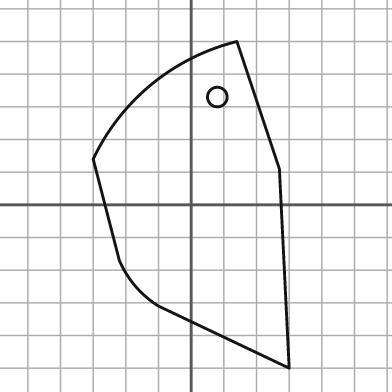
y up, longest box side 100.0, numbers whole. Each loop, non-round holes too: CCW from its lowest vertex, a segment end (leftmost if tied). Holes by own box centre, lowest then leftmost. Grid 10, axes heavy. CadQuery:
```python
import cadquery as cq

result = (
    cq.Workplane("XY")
    .moveTo(30.0, -50.0)
    .lineTo(27.0, 11.0)
    .lineTo(14.0, 50.0)
    .threePointArc((-12.0, 37.0), (-30.0, 14.0))
    .lineTo(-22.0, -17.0)
    .threePointArc((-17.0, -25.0), (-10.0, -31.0))
    .close()
    .moveTo(8.0, 33.0)
    .circle(3.0)
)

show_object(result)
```